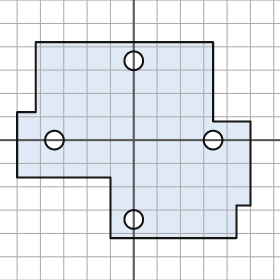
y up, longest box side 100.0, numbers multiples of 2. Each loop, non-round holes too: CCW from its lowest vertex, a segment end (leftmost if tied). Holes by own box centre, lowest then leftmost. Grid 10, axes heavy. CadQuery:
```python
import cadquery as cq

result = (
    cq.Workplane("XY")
    .moveTo(-10.0, -42.0)
    .lineTo(44.0, -42.0)
    .lineTo(44.0, -28.0)
    .lineTo(50.0, -28.0)
    .lineTo(50.0, 8.0)
    .lineTo(34.0, 8.0)
    .lineTo(34.0, 42.0)
    .lineTo(-42.0, 42.0)
    .lineTo(-42.0, 12.0)
    .lineTo(-50.0, 12.0)
    .lineTo(-50.0, -16.0)
    .lineTo(-10.0, -16.0)
    .close()
    .moveTo(0.0, -34.0)
    .circle(4.0)
    .moveTo(-34.0, 0.0)
    .circle(4.0)
    .moveTo(34.0, 0.0)
    .circle(4.0)
    .moveTo(0.0, 34.0)
    .circle(4.0)
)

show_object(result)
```